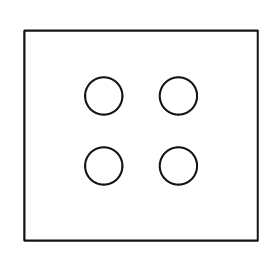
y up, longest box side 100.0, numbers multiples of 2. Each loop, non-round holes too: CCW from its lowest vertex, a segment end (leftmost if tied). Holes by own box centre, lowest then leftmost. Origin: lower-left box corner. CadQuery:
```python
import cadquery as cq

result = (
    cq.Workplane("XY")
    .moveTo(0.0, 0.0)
    .lineTo(100.0, 0.0)
    .lineTo(100.0, 90.0)
    .lineTo(0.0, 90.0)
    .close()
    .moveTo(34.0, 32.0)
    .circle(8.0)
    .moveTo(66.0, 32.0)
    .circle(8.0)
    .moveTo(34.0, 62.0)
    .circle(8.0)
    .moveTo(66.0, 62.0)
    .circle(8.0)
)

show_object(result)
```